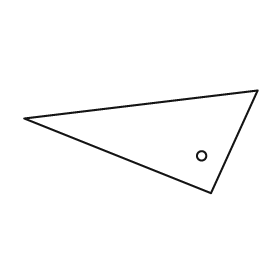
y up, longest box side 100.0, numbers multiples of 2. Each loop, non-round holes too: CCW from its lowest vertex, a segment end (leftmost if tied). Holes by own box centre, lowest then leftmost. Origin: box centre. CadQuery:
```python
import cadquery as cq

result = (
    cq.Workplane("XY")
    .moveTo(30.0, -22.0)
    .lineTo(50.0, 22.0)
    .lineTo(-50.0, 10.0)
    .close()
    .moveTo(26.0, -6.0)
    .circle(2.0)
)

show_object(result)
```